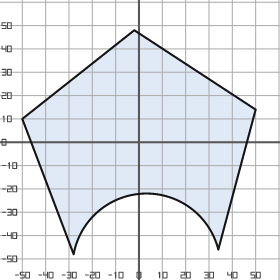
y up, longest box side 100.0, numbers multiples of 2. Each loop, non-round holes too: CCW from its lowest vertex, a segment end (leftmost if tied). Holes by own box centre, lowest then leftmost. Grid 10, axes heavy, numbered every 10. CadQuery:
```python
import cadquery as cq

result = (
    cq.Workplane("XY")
    .moveTo(-28.0, -48.0)
    .threePointArc((2.0, -22.0), (34.0, -46.0))
    .lineTo(50.0, 14.0)
    .lineTo(-2.0, 48.0)
    .lineTo(-50.0, 10.0)
    .close()
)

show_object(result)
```